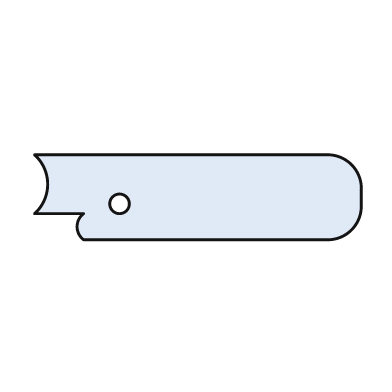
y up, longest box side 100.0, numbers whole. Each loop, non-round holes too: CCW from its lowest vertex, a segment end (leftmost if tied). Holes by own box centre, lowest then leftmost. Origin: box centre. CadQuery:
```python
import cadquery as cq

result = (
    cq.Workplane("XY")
    .moveTo(-35.0, -13.0)
    .lineTo(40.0, -13.0)
    .threePointArc((47.0, -10.0), (50.0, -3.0))
    .lineTo(50.0, 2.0)
    .threePointArc((47.0, 10.0), (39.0, 13.0))
    .lineTo(-50.0, 13.0)
    .threePointArc((-46.0, 4.0), (-50.0, -5.0))
    .lineTo(-35.0, -5.0)
    .threePointArc((-37.0, -9.0), (-35.0, -13.0))
    .close()
    .moveTo(-24.0, -2.0)
    .circle(3.0)
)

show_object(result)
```